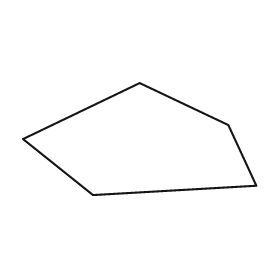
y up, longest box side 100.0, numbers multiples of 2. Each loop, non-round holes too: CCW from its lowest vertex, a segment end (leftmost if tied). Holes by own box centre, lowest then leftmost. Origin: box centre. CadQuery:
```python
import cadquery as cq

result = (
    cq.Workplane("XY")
    .moveTo(-20.0, -24.0)
    .lineTo(50.0, -20.0)
    .lineTo(38.0, 6.0)
    .lineTo(0.0, 24.0)
    .lineTo(-50.0, 0.0)
    .close()
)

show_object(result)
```